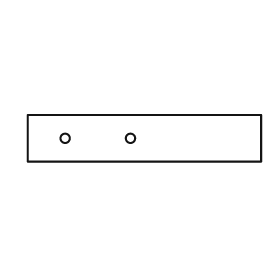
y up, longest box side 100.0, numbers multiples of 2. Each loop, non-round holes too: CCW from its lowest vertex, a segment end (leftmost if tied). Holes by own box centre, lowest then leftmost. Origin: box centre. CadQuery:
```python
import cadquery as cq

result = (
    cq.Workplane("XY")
    .moveTo(-50.0, -10.0)
    .lineTo(50.0, -10.0)
    .lineTo(50.0, 10.0)
    .lineTo(-50.0, 10.0)
    .close()
    .moveTo(-34.0, 0.0)
    .circle(2.0)
    .moveTo(-6.0, 0.0)
    .circle(2.0)
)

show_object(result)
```